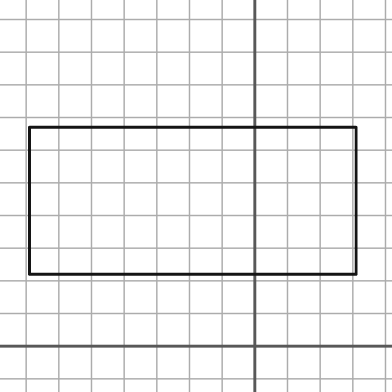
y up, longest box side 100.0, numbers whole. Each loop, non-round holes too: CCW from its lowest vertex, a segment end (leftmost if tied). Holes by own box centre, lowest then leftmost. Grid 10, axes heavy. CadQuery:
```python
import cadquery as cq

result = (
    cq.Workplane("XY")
    .moveTo(-69.0, 22.0)
    .lineTo(31.0, 22.0)
    .lineTo(31.0, 67.0)
    .lineTo(-69.0, 67.0)
    .close()
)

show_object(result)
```